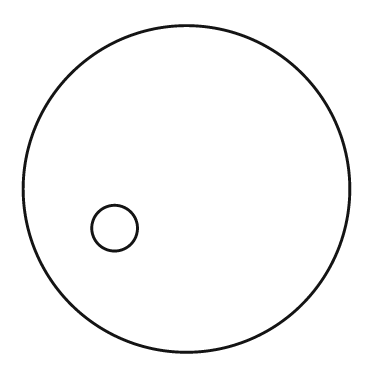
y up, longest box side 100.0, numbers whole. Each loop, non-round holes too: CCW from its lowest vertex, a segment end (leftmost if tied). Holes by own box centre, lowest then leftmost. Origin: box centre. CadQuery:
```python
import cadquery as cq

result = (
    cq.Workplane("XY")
    .moveTo(0.0, 0.0)
    .circle(50.0)
    .moveTo(-22.0, -12.0)
    .circle(7.0)
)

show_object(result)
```